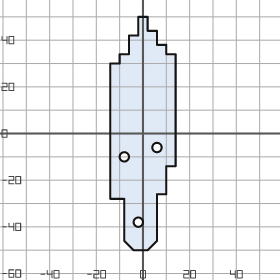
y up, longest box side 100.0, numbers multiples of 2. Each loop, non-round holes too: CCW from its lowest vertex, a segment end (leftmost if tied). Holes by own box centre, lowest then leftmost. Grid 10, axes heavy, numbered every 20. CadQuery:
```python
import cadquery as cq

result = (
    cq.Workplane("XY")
    .moveTo(-4.0, -50.0)
    .lineTo(2.0, -50.0)
    .lineTo(6.0, -46.0)
    .lineTo(6.0, -26.0)
    .lineTo(10.0, -26.0)
    .lineTo(10.0, -14.0)
    .lineTo(14.0, -14.0)
    .lineTo(14.0, 34.0)
    .lineTo(10.0, 34.0)
    .lineTo(10.0, 38.0)
    .lineTo(6.0, 38.0)
    .lineTo(6.0, 44.0)
    .lineTo(2.0, 44.0)
    .lineTo(2.0, 50.0)
    .lineTo(-2.0, 50.0)
    .lineTo(-2.0, 42.0)
    .lineTo(-6.0, 42.0)
    .lineTo(-6.0, 34.0)
    .lineTo(-10.0, 34.0)
    .lineTo(-10.0, 30.0)
    .lineTo(-14.0, 30.0)
    .lineTo(-14.0, -28.0)
    .lineTo(-8.0, -28.0)
    .lineTo(-8.0, -46.0)
    .close()
    .moveTo(-2.0, -38.0)
    .circle(2.0)
    .moveTo(-8.0, -10.0)
    .circle(2.0)
    .moveTo(6.0, -6.0)
    .circle(2.0)
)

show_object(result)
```